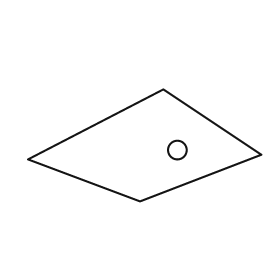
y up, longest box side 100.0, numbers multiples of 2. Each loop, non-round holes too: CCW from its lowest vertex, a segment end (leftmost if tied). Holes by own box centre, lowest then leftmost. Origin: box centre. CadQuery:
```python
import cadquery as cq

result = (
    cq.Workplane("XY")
    .moveTo(-2.0, -24.0)
    .lineTo(50.0, -4.0)
    .lineTo(8.0, 24.0)
    .lineTo(-50.0, -6.0)
    .close()
    .moveTo(14.0, -2.0)
    .circle(4.0)
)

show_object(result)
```